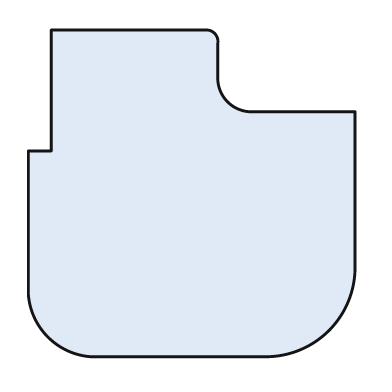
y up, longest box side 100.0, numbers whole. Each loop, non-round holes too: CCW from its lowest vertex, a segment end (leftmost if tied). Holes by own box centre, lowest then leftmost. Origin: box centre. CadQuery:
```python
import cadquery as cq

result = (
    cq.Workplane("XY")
    .moveTo(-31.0, -50.0)
    .lineTo(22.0, -50.0)
    .threePointArc((42.0, -42.0), (50.0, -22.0))
    .lineTo(50.0, 25.0)
    .lineTo(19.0, 25.0)
    .threePointArc((11.0, 28.0), (8.0, 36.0))
    .lineTo(8.0, 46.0)
    .threePointArc((7.0, 49.0), (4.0, 50.0))
    .lineTo(-43.0, 50.0)
    .lineTo(-43.0, 13.0)
    .lineTo(-50.0, 13.0)
    .lineTo(-50.0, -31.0)
    .threePointArc((-44.0, -44.0), (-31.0, -50.0))
    .close()
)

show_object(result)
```